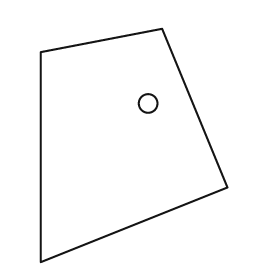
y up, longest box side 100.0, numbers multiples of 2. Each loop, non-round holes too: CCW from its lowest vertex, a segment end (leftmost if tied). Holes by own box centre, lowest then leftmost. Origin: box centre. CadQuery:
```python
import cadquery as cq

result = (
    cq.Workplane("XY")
    .moveTo(-40.0, -50.0)
    .lineTo(40.0, -18.0)
    .lineTo(12.0, 50.0)
    .lineTo(-40.0, 40.0)
    .close()
    .moveTo(6.0, 18.0)
    .circle(4.0)
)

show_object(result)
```